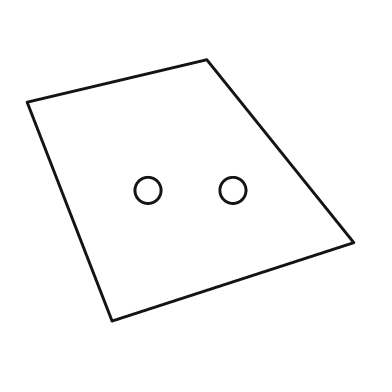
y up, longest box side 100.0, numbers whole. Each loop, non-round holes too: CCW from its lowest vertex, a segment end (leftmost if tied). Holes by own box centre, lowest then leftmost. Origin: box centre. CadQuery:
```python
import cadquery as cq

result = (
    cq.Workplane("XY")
    .moveTo(-24.0, -40.0)
    .lineTo(50.0, -16.0)
    .lineTo(5.0, 40.0)
    .lineTo(-50.0, 27.0)
    .close()
    .moveTo(-13.0, 0.0)
    .circle(4.0)
    .moveTo(13.0, 0.0)
    .circle(4.0)
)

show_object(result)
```